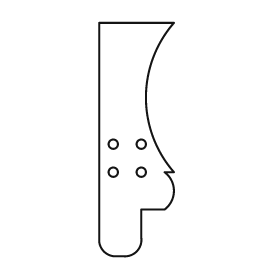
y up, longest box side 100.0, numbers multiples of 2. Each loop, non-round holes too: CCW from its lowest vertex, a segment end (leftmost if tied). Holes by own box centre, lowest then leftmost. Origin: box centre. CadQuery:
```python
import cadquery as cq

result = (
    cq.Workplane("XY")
    .moveTo(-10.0, -50.0)
    .lineTo(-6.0, -50.0)
    .threePointArc((0.0, -48.0), (2.0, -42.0))
    .lineTo(2.0, -30.0)
    .lineTo(12.0, -30.0)
    .threePointArc((16.0, -22.0), (12.0, -14.0))
    .lineTo(16.0, -14.0)
    .threePointArc((4.0, 18.0), (16.0, 50.0))
    .lineTo(-16.0, 50.0)
    .lineTo(-16.0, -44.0)
    .threePointArc((-14.0, -48.0), (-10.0, -50.0))
    .close()
    .moveTo(-10.0, -14.0)
    .circle(2.0)
    .moveTo(2.0, -14.0)
    .circle(2.0)
    .moveTo(-10.0, -2.0)
    .circle(2.0)
    .moveTo(2.0, -2.0)
    .circle(2.0)
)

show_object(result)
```